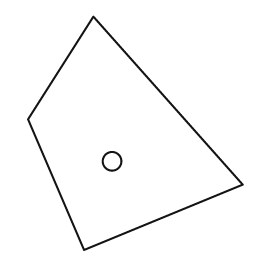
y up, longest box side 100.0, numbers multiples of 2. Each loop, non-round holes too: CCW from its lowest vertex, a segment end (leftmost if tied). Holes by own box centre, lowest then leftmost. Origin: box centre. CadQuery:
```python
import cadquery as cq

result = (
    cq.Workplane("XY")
    .moveTo(-22.0, -50.0)
    .lineTo(46.0, -22.0)
    .lineTo(-18.0, 50.0)
    .lineTo(-46.0, 6.0)
    .close()
    .moveTo(-10.0, -12.0)
    .circle(4.0)
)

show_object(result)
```